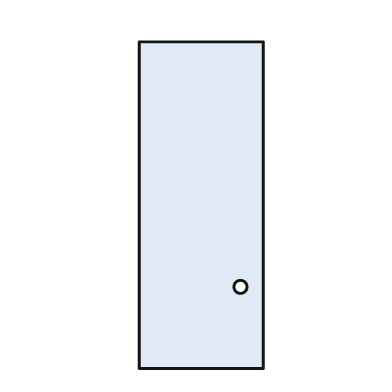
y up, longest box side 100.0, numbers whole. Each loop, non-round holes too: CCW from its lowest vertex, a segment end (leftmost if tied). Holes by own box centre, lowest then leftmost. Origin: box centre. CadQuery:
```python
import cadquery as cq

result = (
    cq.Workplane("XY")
    .moveTo(-19.0, -50.0)
    .lineTo(19.0, -50.0)
    .lineTo(19.0, 50.0)
    .lineTo(-19.0, 50.0)
    .close()
    .moveTo(12.0, -25.0)
    .circle(2.0)
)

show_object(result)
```